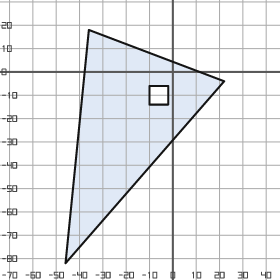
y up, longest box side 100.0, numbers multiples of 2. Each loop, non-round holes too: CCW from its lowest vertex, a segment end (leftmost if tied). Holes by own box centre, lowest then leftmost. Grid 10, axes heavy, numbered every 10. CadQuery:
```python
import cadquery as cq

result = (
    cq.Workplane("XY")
    .moveTo(-46.0, -82.0)
    .lineTo(22.0, -4.0)
    .lineTo(-36.0, 18.0)
    .close()
    .moveTo(-10.0, -14.0)
    .lineTo(-2.0, -14.0)
    .lineTo(-2.0, -6.0)
    .lineTo(-10.0, -6.0)
    .close()
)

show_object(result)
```